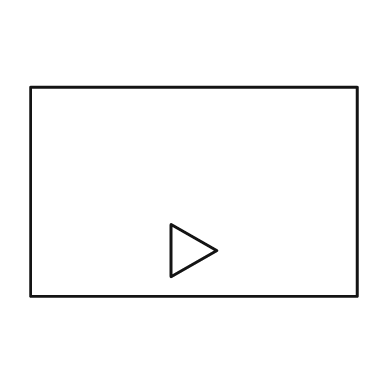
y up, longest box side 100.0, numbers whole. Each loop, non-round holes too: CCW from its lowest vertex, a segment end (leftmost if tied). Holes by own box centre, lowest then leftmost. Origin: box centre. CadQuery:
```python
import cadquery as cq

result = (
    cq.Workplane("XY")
    .moveTo(-50.0, -32.0)
    .lineTo(50.0, -32.0)
    .lineTo(50.0, 32.0)
    .lineTo(-50.0, 32.0)
    .close()
    .moveTo(-7.0, -26.0)
    .lineTo(7.0, -18.0)
    .lineTo(-7.0, -10.0)
    .close()
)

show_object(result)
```